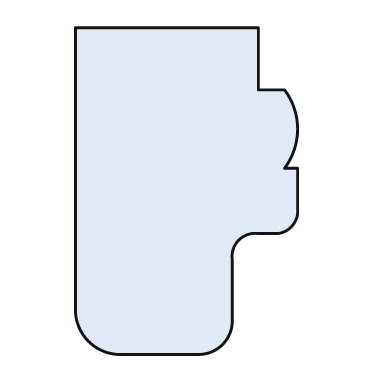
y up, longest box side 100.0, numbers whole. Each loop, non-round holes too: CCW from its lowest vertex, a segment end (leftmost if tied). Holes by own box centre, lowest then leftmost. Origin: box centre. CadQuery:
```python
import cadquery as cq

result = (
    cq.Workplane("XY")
    .moveTo(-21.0, -50.0)
    .lineTo(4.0, -50.0)
    .threePointArc((11.0, -47.0), (14.0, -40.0))
    .lineTo(14.0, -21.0)
    .threePointArc((16.0, -15.0), (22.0, -13.0))
    .lineTo(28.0, -13.0)
    .threePointArc((32.0, -11.0), (34.0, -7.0))
    .lineTo(34.0, 7.0)
    .lineTo(30.0, 7.0)
    .threePointArc((34.0, 19.0), (30.0, 31.0))
    .lineTo(22.0, 31.0)
    .lineTo(22.0, 50.0)
    .lineTo(-34.0, 50.0)
    .lineTo(-34.0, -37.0)
    .threePointArc((-30.0, -46.0), (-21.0, -50.0))
    .close()
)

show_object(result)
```